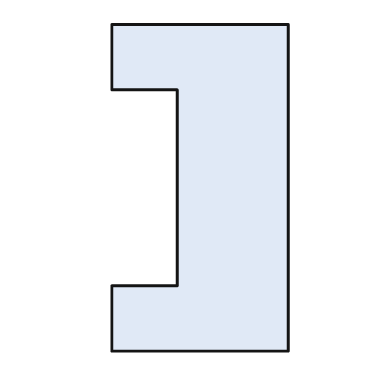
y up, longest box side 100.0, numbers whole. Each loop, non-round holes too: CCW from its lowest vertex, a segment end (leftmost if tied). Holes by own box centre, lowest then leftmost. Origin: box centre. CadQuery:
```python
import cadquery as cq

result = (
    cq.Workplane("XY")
    .moveTo(-27.0, -50.0)
    .lineTo(27.0, -50.0)
    .lineTo(27.0, 50.0)
    .lineTo(-27.0, 50.0)
    .lineTo(-27.0, 30.0)
    .lineTo(-7.0, 30.0)
    .lineTo(-7.0, -30.0)
    .lineTo(-27.0, -30.0)
    .close()
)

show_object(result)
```